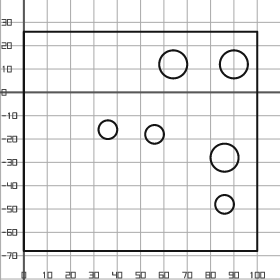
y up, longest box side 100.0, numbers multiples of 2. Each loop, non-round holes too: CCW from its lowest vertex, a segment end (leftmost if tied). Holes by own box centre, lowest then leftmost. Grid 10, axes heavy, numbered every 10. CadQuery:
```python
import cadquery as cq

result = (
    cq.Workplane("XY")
    .moveTo(0.0, -68.0)
    .lineTo(100.0, -68.0)
    .lineTo(100.0, 26.0)
    .lineTo(0.0, 26.0)
    .close()
    .moveTo(86.0, -48.0)
    .circle(4.0)
    .moveTo(86.0, -28.0)
    .circle(6.0)
    .moveTo(56.0, -18.0)
    .circle(4.0)
    .moveTo(36.0, -16.0)
    .circle(4.0)
    .moveTo(64.0, 12.0)
    .circle(6.0)
    .moveTo(90.0, 12.0)
    .circle(6.0)
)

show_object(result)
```